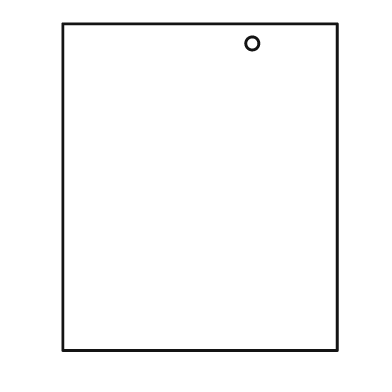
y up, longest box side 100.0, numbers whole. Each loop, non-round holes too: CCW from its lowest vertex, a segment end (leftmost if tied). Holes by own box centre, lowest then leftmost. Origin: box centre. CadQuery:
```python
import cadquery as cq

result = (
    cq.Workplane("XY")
    .moveTo(-42.0, -50.0)
    .lineTo(42.0, -50.0)
    .lineTo(42.0, 50.0)
    .lineTo(-42.0, 50.0)
    .close()
    .moveTo(16.0, 44.0)
    .circle(2.0)
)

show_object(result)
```